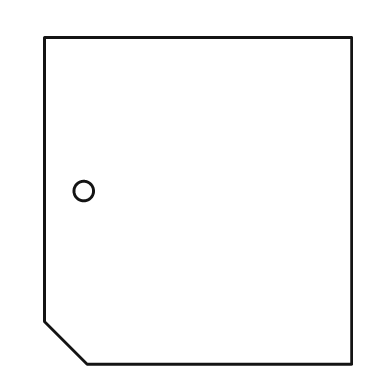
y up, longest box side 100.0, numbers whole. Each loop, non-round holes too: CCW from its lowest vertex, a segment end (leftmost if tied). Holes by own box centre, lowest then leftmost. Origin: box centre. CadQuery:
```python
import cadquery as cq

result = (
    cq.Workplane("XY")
    .moveTo(-34.0, -50.0)
    .lineTo(47.0, -50.0)
    .lineTo(47.0, 50.0)
    .lineTo(-47.0, 50.0)
    .lineTo(-47.0, -37.0)
    .close()
    .moveTo(-35.0, 3.0)
    .circle(3.0)
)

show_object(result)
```